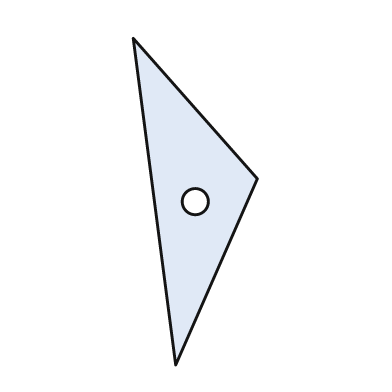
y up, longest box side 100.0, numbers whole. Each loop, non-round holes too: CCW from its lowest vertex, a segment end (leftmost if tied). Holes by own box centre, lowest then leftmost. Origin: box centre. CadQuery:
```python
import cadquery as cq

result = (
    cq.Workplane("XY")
    .moveTo(-6.0, -50.0)
    .lineTo(19.0, 7.0)
    .lineTo(-19.0, 50.0)
    .close()
    .moveTo(0.0, 0.0)
    .circle(4.0)
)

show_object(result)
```